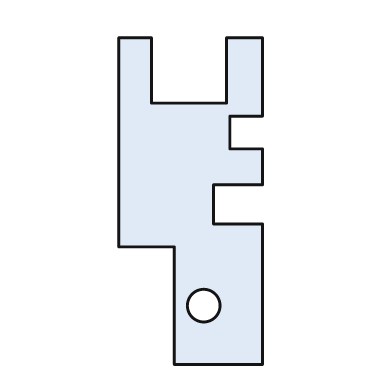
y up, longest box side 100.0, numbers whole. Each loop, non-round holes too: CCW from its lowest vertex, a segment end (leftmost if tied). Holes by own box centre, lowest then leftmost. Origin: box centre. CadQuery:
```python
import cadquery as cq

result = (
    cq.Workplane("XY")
    .moveTo(-5.0, -50.0)
    .lineTo(22.0, -50.0)
    .lineTo(22.0, -7.0)
    .lineTo(7.0, -7.0)
    .lineTo(7.0, 5.0)
    .lineTo(22.0, 5.0)
    .lineTo(22.0, 16.0)
    .lineTo(12.0, 16.0)
    .lineTo(12.0, 26.0)
    .lineTo(22.0, 26.0)
    .lineTo(22.0, 50.0)
    .lineTo(11.0, 50.0)
    .lineTo(11.0, 30.0)
    .lineTo(-12.0, 30.0)
    .lineTo(-12.0, 50.0)
    .lineTo(-22.0, 50.0)
    .lineTo(-22.0, -14.0)
    .lineTo(-5.0, -14.0)
    .close()
    .moveTo(4.0, -32.0)
    .circle(5.0)
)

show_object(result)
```